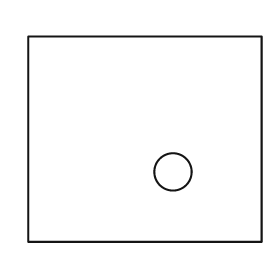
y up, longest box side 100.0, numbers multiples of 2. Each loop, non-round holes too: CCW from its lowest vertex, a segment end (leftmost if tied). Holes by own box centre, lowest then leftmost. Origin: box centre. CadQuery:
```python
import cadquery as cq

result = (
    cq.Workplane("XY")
    .moveTo(-50.0, -44.0)
    .lineTo(50.0, -44.0)
    .lineTo(50.0, 44.0)
    .lineTo(-50.0, 44.0)
    .close()
    .moveTo(12.0, -14.0)
    .circle(8.0)
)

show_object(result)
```